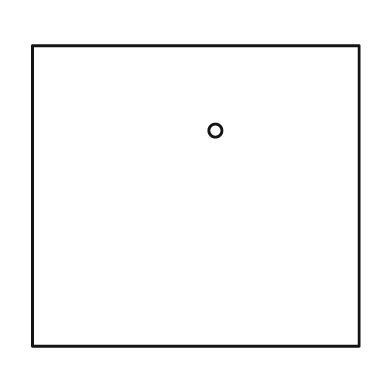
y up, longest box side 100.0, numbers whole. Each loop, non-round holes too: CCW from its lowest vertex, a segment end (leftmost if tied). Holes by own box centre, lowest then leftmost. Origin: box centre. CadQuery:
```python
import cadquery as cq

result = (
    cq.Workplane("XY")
    .moveTo(-50.0, -46.0)
    .lineTo(50.0, -46.0)
    .lineTo(50.0, 46.0)
    .lineTo(-50.0, 46.0)
    .close()
    .moveTo(6.0, 20.0)
    .circle(2.0)
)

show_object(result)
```